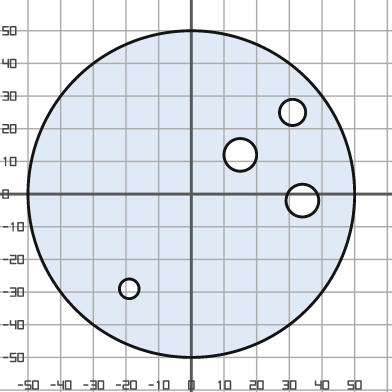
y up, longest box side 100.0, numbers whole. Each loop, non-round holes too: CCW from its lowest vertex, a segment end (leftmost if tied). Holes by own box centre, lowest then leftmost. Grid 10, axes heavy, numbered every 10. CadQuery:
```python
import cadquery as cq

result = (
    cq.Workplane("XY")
    .moveTo(0.0, 0.0)
    .circle(50.0)
    .moveTo(-19.0, -29.0)
    .circle(3.0)
    .moveTo(34.0, -2.0)
    .circle(5.0)
    .moveTo(15.0, 12.0)
    .circle(5.0)
    .moveTo(31.0, 25.0)
    .circle(4.0)
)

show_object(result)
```